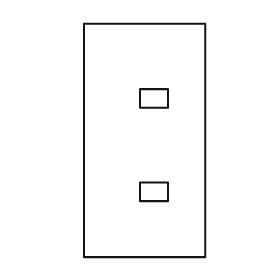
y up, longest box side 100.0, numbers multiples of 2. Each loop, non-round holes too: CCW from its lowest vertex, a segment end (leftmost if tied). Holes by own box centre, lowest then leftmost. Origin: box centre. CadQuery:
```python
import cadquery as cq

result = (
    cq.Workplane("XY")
    .moveTo(-26.0, -50.0)
    .lineTo(26.0, -50.0)
    .lineTo(26.0, 50.0)
    .lineTo(-26.0, 50.0)
    .close()
    .moveTo(-2.0, -26.0)
    .lineTo(10.0, -26.0)
    .lineTo(10.0, -18.0)
    .lineTo(-2.0, -18.0)
    .close()
    .moveTo(-2.0, 14.0)
    .lineTo(10.0, 14.0)
    .lineTo(10.0, 22.0)
    .lineTo(-2.0, 22.0)
    .close()
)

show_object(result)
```